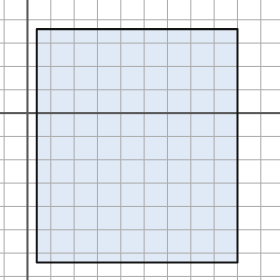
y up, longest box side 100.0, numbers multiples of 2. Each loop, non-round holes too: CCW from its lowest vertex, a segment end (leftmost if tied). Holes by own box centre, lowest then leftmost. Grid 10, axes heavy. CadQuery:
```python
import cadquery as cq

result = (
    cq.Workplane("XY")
    .moveTo(4.0, -64.0)
    .lineTo(90.0, -64.0)
    .lineTo(90.0, 36.0)
    .lineTo(4.0, 36.0)
    .close()
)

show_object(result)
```